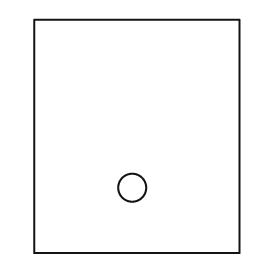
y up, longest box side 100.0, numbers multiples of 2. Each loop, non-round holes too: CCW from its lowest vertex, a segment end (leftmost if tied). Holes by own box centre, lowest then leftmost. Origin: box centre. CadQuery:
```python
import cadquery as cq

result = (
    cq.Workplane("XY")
    .moveTo(-44.0, -50.0)
    .lineTo(44.0, -50.0)
    .lineTo(44.0, 50.0)
    .lineTo(-44.0, 50.0)
    .close()
    .moveTo(-2.0, -22.0)
    .circle(6.0)
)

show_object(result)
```